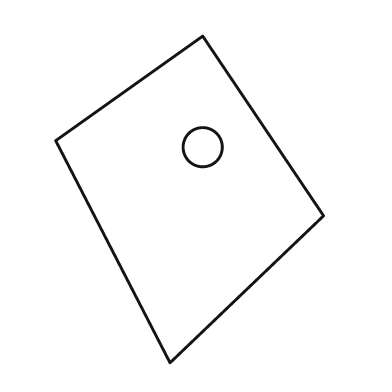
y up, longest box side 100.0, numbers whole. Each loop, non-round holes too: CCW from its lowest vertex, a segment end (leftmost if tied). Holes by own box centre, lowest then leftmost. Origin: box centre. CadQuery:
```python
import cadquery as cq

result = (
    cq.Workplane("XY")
    .moveTo(-6.0, -50.0)
    .lineTo(41.0, -5.0)
    .lineTo(4.0, 50.0)
    .lineTo(-41.0, 18.0)
    .close()
    .moveTo(4.0, 16.0)
    .circle(6.0)
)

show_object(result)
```